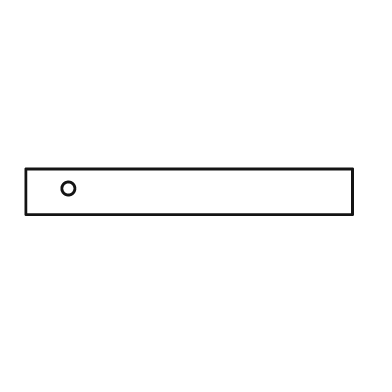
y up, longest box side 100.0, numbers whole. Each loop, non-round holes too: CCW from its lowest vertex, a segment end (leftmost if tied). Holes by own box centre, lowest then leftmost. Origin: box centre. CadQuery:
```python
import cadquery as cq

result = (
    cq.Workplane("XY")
    .moveTo(-50.0, -7.0)
    .lineTo(50.0, -7.0)
    .lineTo(50.0, 7.0)
    .lineTo(-50.0, 7.0)
    .close()
    .moveTo(-37.0, 1.0)
    .circle(2.0)
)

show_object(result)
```